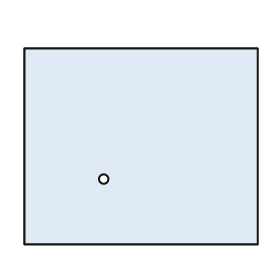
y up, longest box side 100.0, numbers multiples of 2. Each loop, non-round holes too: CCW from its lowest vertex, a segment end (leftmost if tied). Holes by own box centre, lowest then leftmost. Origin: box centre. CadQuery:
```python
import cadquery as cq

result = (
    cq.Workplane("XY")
    .moveTo(-50.0, -42.0)
    .lineTo(50.0, -42.0)
    .lineTo(50.0, 42.0)
    .lineTo(-50.0, 42.0)
    .close()
    .moveTo(-16.0, -14.0)
    .circle(2.0)
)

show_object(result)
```